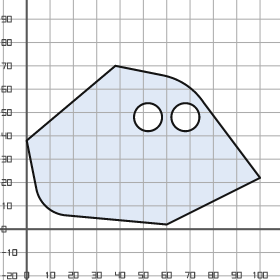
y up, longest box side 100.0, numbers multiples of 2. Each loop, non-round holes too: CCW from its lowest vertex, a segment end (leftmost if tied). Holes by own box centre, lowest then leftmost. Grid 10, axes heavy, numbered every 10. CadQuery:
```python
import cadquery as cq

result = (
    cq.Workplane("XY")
    .moveTo(60.0, 2.0)
    .lineTo(100.0, 22.0)
    .lineTo(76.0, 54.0)
    .threePointArc((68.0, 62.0), (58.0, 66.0))
    .lineTo(38.0, 70.0)
    .lineTo(0.0, 38.0)
    .lineTo(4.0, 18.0)
    .threePointArc((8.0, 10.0), (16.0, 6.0))
    .close()
    .moveTo(52.0, 48.0)
    .circle(6.0)
    .moveTo(68.0, 48.0)
    .circle(6.0)
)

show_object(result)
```